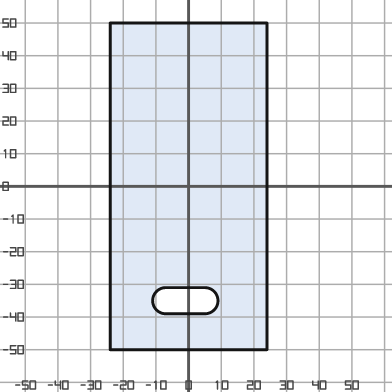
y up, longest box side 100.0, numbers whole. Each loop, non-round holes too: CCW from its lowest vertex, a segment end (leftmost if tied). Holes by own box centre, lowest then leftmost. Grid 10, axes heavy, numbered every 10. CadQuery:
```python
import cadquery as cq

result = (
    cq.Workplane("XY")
    .moveTo(-24.0, -50.0)
    .lineTo(24.0, -50.0)
    .lineTo(24.0, 50.0)
    .lineTo(-24.0, 50.0)
    .close()
    .moveTo(-7.0, -39.0)
    .lineTo(5.0, -39.0)
    .threePointArc((9.0, -35.0), (5.0, -31.0))
    .lineTo(-7.0, -31.0)
    .threePointArc((-11.0, -35.0), (-7.0, -39.0))
    .close()
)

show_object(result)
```